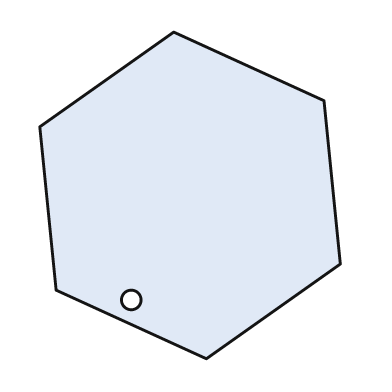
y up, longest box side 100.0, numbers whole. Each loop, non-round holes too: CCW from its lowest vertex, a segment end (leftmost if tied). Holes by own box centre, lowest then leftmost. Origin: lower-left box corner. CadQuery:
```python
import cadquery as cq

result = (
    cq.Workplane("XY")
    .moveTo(51.0, 0.0)
    .lineTo(92.0, 29.0)
    .lineTo(87.0, 79.0)
    .lineTo(41.0, 100.0)
    .lineTo(0.0, 71.0)
    .lineTo(5.0, 21.0)
    .close()
    .moveTo(28.0, 18.0)
    .circle(3.0)
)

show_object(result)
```